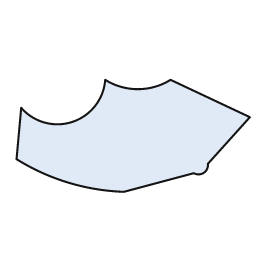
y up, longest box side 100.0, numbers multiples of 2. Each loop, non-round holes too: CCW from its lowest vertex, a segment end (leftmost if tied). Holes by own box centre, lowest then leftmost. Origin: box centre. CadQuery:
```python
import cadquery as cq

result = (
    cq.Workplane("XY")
    .moveTo(-4.0, -24.0)
    .lineTo(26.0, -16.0)
    .threePointArc((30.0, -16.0), (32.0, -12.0))
    .lineTo(50.0, 8.0)
    .lineTo(16.0, 24.0)
    .threePointArc((2.0, 20.0), (-12.0, 24.0))
    .threePointArc((-26.0, 6.0), (-48.0, 12.0))
    .lineTo(-50.0, -10.0)
    .threePointArc((-28.0, -20.0), (-4.0, -24.0))
    .close()
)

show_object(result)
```